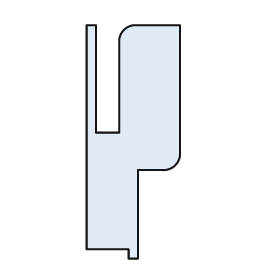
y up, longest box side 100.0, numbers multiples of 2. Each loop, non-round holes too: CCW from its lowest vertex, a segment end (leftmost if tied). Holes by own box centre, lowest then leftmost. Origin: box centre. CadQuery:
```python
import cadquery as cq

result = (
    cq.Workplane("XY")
    .moveTo(-2.0, -50.0)
    .lineTo(2.0, -50.0)
    .lineTo(2.0, -12.0)
    .lineTo(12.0, -12.0)
    .threePointArc((18.0, -10.0), (20.0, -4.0))
    .lineTo(20.0, 50.0)
    .lineTo(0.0, 50.0)
    .threePointArc((-4.0, 48.0), (-6.0, 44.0))
    .lineTo(-6.0, 4.0)
    .lineTo(-16.0, 4.0)
    .lineTo(-16.0, 50.0)
    .lineTo(-20.0, 50.0)
    .lineTo(-20.0, -46.0)
    .lineTo(-2.0, -46.0)
    .close()
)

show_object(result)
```